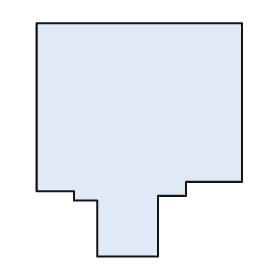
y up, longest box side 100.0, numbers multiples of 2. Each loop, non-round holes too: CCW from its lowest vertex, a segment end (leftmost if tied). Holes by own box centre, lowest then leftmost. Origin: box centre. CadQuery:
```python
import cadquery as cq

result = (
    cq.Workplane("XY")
    .moveTo(-18.0, -50.0)
    .lineTo(8.0, -50.0)
    .lineTo(8.0, -24.0)
    .lineTo(20.0, -24.0)
    .lineTo(20.0, -18.0)
    .lineTo(44.0, -18.0)
    .lineTo(44.0, 50.0)
    .lineTo(-44.0, 50.0)
    .lineTo(-44.0, -22.0)
    .lineTo(-28.0, -22.0)
    .lineTo(-28.0, -26.0)
    .lineTo(-18.0, -26.0)
    .close()
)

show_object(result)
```